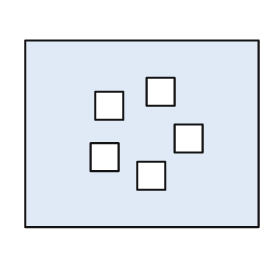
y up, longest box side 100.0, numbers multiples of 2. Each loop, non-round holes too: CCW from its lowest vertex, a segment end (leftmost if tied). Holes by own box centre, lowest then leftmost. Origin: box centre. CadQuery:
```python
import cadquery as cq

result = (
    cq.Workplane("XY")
    .moveTo(-50.0, -40.0)
    .lineTo(50.0, -40.0)
    .lineTo(50.0, 40.0)
    .lineTo(-50.0, 40.0)
    .close()
    .moveTo(-2.0, -24.0)
    .lineTo(10.0, -24.0)
    .lineTo(10.0, -12.0)
    .lineTo(-2.0, -12.0)
    .close()
    .moveTo(-22.0, -16.0)
    .lineTo(-10.0, -16.0)
    .lineTo(-10.0, -4.0)
    .lineTo(-22.0, -4.0)
    .close()
    .moveTo(14.0, -8.0)
    .lineTo(26.0, -8.0)
    .lineTo(26.0, 4.0)
    .lineTo(14.0, 4.0)
    .close()
    .moveTo(-20.0, 6.0)
    .lineTo(-8.0, 6.0)
    .lineTo(-8.0, 18.0)
    .lineTo(-20.0, 18.0)
    .close()
    .moveTo(2.0, 12.0)
    .lineTo(14.0, 12.0)
    .lineTo(14.0, 24.0)
    .lineTo(2.0, 24.0)
    .close()
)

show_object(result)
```